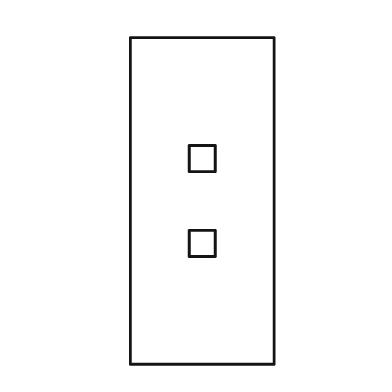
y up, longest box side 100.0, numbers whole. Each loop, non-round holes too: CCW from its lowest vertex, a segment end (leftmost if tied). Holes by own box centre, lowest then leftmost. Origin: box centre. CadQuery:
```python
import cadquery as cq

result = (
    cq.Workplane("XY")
    .moveTo(-22.0, -50.0)
    .lineTo(22.0, -50.0)
    .lineTo(22.0, 50.0)
    .lineTo(-22.0, 50.0)
    .close()
    .moveTo(-4.0, -17.0)
    .lineTo(4.0, -17.0)
    .lineTo(4.0, -9.0)
    .lineTo(-4.0, -9.0)
    .close()
    .moveTo(-4.0, 9.0)
    .lineTo(4.0, 9.0)
    .lineTo(4.0, 17.0)
    .lineTo(-4.0, 17.0)
    .close()
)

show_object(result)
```